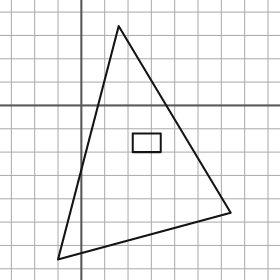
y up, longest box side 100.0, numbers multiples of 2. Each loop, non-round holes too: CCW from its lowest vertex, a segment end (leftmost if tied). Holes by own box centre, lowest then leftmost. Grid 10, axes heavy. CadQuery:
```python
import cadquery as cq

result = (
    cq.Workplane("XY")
    .moveTo(-10.0, -66.0)
    .lineTo(64.0, -46.0)
    .lineTo(16.0, 34.0)
    .close()
    .moveTo(22.0, -20.0)
    .lineTo(34.0, -20.0)
    .lineTo(34.0, -12.0)
    .lineTo(22.0, -12.0)
    .close()
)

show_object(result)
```